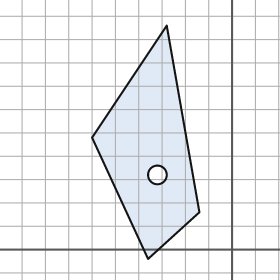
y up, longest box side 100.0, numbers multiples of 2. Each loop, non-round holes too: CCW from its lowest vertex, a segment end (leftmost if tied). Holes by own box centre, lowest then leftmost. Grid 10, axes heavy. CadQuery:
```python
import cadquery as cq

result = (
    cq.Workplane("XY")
    .moveTo(-36.0, -4.0)
    .lineTo(-14.0, 16.0)
    .lineTo(-28.0, 96.0)
    .lineTo(-60.0, 48.0)
    .close()
    .moveTo(-32.0, 32.0)
    .circle(4.0)
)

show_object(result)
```